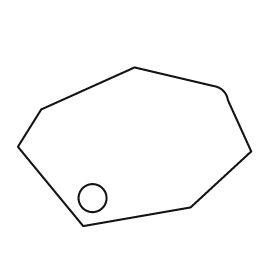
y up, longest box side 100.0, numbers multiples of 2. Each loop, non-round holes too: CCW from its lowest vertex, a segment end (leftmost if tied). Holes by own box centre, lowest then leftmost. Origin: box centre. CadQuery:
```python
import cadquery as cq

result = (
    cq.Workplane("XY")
    .moveTo(-22.0, -34.0)
    .lineTo(24.0, -26.0)
    .lineTo(50.0, -2.0)
    .lineTo(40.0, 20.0)
    .threePointArc((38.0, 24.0), (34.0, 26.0))
    .lineTo(0.0, 34.0)
    .lineTo(-40.0, 16.0)
    .lineTo(-50.0, 0.0)
    .close()
    .moveTo(-18.0, -22.0)
    .circle(6.0)
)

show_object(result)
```